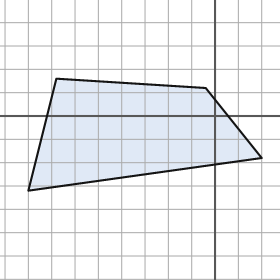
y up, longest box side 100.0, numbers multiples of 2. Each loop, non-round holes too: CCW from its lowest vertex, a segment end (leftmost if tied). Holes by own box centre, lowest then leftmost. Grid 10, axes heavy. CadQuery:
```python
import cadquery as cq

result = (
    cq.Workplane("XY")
    .moveTo(-80.0, -32.0)
    .lineTo(20.0, -18.0)
    .lineTo(-4.0, 12.0)
    .lineTo(-68.0, 16.0)
    .close()
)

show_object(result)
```